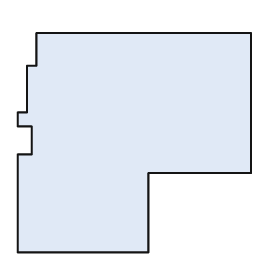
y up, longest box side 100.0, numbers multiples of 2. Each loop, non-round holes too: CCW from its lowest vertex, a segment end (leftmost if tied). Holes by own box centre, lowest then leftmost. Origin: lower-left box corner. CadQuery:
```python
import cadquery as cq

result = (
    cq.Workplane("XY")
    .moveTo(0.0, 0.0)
    .lineTo(56.0, 0.0)
    .lineTo(56.0, 34.0)
    .lineTo(100.0, 34.0)
    .lineTo(100.0, 94.0)
    .lineTo(8.0, 94.0)
    .lineTo(8.0, 80.0)
    .lineTo(4.0, 80.0)
    .lineTo(4.0, 60.0)
    .lineTo(0.0, 60.0)
    .lineTo(0.0, 54.0)
    .lineTo(6.0, 54.0)
    .lineTo(6.0, 42.0)
    .lineTo(0.0, 42.0)
    .close()
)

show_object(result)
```